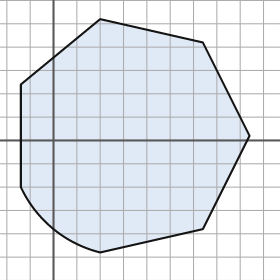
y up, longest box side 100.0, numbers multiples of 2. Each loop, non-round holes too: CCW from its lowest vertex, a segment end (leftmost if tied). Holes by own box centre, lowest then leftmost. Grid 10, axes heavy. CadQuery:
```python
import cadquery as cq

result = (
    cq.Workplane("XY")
    .moveTo(20.0, -48.0)
    .lineTo(64.0, -38.0)
    .lineTo(84.0, 2.0)
    .lineTo(64.0, 42.0)
    .lineTo(20.0, 52.0)
    .lineTo(-14.0, 24.0)
    .lineTo(-14.0, -20.0)
    .threePointArc((0.0, -38.0), (20.0, -48.0))
    .close()
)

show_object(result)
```